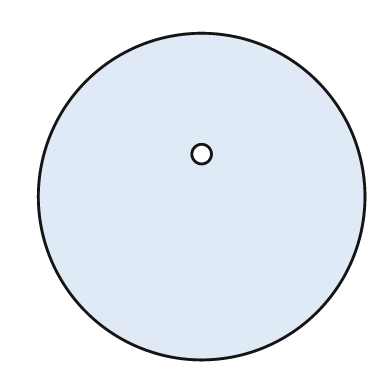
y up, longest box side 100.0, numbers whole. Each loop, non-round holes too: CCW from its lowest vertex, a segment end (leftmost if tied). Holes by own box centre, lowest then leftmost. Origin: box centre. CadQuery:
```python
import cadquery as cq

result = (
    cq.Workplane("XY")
    .moveTo(0.0, 0.0)
    .circle(50.0)
    .moveTo(0.0, 13.0)
    .circle(3.0)
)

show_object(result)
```